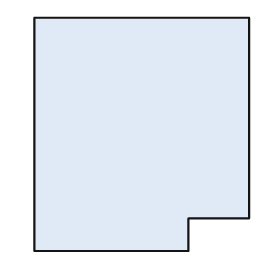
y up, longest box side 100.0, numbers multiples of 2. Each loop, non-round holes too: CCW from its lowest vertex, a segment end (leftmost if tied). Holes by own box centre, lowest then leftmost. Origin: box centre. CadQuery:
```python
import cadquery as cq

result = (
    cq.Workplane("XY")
    .moveTo(-46.0, -50.0)
    .lineTo(20.0, -50.0)
    .lineTo(20.0, -36.0)
    .lineTo(46.0, -36.0)
    .lineTo(46.0, 50.0)
    .lineTo(-46.0, 50.0)
    .close()
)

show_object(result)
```